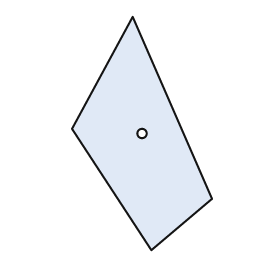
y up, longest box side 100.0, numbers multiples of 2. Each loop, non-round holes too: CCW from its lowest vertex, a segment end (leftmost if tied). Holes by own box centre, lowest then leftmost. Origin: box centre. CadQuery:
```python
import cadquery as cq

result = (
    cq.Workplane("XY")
    .moveTo(4.0, -50.0)
    .lineTo(30.0, -28.0)
    .lineTo(-4.0, 50.0)
    .lineTo(-30.0, 2.0)
    .close()
    .moveTo(0.0, 0.0)
    .circle(2.0)
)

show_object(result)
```